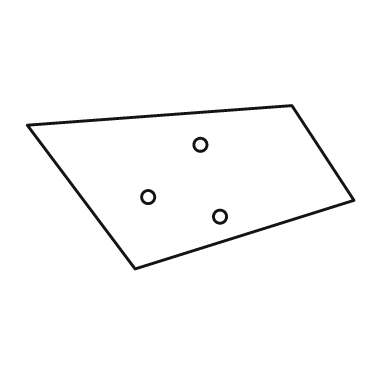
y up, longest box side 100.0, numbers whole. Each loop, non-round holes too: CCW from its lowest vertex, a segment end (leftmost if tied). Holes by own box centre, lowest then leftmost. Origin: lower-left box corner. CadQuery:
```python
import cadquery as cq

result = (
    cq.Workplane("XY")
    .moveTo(33.0, 0.0)
    .lineTo(100.0, 21.0)
    .lineTo(81.0, 50.0)
    .lineTo(0.0, 44.0)
    .close()
    .moveTo(59.0, 16.0)
    .circle(2.0)
    .moveTo(37.0, 22.0)
    .circle(2.0)
    .moveTo(53.0, 38.0)
    .circle(2.0)
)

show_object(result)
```